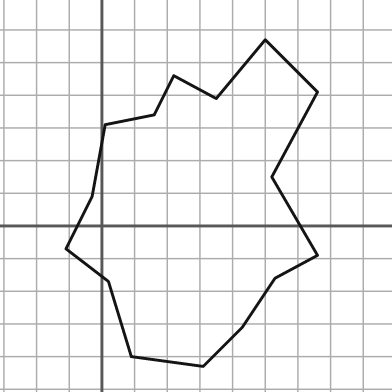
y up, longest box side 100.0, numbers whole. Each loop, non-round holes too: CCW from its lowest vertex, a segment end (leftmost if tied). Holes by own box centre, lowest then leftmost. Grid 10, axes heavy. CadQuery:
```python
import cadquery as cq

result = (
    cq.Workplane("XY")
    .moveTo(31.0, -43.0)
    .lineTo(43.0, -31.0)
    .lineTo(53.0, -16.0)
    .lineTo(66.0, -9.0)
    .lineTo(52.0, 15.0)
    .lineTo(66.0, 41.0)
    .lineTo(50.0, 57.0)
    .lineTo(35.0, 39.0)
    .lineTo(22.0, 46.0)
    .lineTo(16.0, 34.0)
    .lineTo(1.0, 31.0)
    .lineTo(-3.0, 9.0)
    .lineTo(-11.0, -7.0)
    .lineTo(2.0, -17.0)
    .lineTo(9.0, -40.0)
    .close()
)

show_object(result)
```